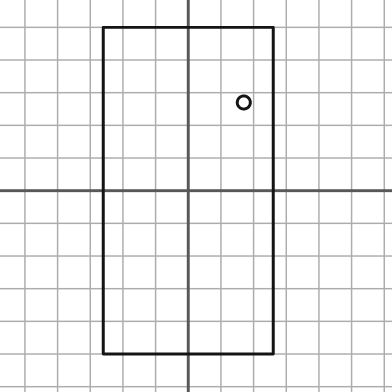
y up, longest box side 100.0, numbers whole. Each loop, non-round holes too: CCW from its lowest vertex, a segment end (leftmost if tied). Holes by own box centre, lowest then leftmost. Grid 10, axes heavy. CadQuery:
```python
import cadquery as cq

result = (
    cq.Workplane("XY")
    .moveTo(-26.0, -50.0)
    .lineTo(26.0, -50.0)
    .lineTo(26.0, 50.0)
    .lineTo(-26.0, 50.0)
    .close()
    .moveTo(17.0, 27.0)
    .circle(2.0)
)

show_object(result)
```